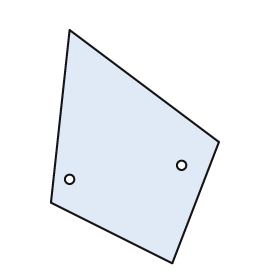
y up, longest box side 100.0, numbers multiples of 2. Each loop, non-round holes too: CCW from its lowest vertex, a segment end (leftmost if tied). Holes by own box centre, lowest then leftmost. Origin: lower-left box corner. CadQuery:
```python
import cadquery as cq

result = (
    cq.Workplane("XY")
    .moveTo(52.0, 0.0)
    .lineTo(72.0, 52.0)
    .lineTo(8.0, 100.0)
    .lineTo(0.0, 26.0)
    .close()
    .moveTo(8.0, 36.0)
    .circle(2.0)
    .moveTo(56.0, 42.0)
    .circle(2.0)
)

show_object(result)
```